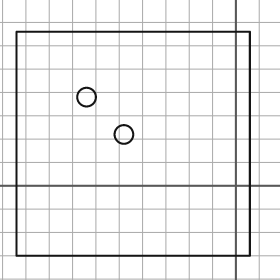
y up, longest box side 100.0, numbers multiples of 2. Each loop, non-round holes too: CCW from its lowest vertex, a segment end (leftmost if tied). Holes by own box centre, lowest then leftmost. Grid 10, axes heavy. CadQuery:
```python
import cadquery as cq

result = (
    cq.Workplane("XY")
    .moveTo(-94.0, -30.0)
    .lineTo(6.0, -30.0)
    .lineTo(6.0, 66.0)
    .lineTo(-94.0, 66.0)
    .close()
    .moveTo(-48.0, 22.0)
    .circle(4.0)
    .moveTo(-64.0, 38.0)
    .circle(4.0)
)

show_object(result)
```